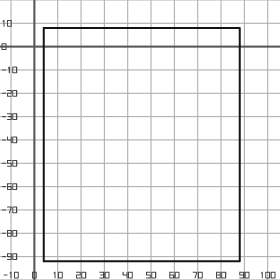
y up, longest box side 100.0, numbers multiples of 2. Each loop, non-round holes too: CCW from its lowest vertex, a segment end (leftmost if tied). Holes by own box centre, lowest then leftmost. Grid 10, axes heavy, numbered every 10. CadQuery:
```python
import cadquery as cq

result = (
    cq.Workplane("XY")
    .moveTo(4.0, -92.0)
    .lineTo(88.0, -92.0)
    .lineTo(88.0, 8.0)
    .lineTo(4.0, 8.0)
    .close()
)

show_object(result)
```